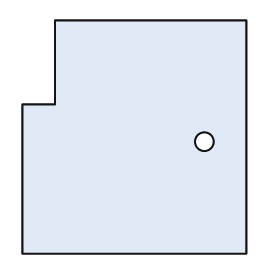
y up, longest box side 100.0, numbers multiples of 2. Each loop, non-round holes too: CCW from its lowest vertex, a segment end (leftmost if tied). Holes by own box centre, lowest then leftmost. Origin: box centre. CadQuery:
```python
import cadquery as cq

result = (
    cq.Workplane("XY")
    .moveTo(-48.0, -50.0)
    .lineTo(48.0, -50.0)
    .lineTo(48.0, 50.0)
    .lineTo(-34.0, 50.0)
    .lineTo(-34.0, 14.0)
    .lineTo(-48.0, 14.0)
    .close()
    .moveTo(30.0, -2.0)
    .circle(4.0)
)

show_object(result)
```